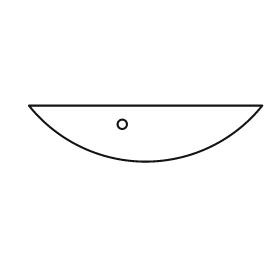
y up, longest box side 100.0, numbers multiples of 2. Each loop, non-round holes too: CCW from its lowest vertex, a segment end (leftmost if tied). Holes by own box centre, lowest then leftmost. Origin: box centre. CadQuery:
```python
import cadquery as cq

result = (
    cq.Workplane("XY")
    .moveTo(-50.0, 12.0)
    .threePointArc((0.0, -12.0), (50.0, 12.0))
    .close()
    .moveTo(-10.0, 4.0)
    .circle(2.0)
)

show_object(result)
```